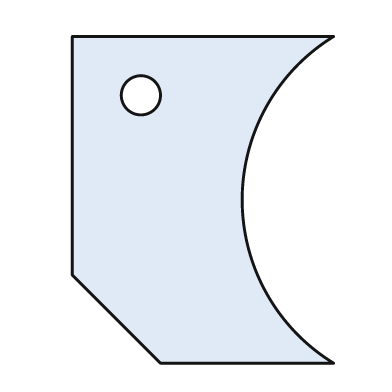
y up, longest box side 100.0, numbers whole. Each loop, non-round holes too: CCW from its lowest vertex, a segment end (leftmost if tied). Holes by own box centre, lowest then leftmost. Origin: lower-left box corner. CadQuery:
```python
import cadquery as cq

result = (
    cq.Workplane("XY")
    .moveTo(27.0, 0.0)
    .lineTo(80.0, 0.0)
    .threePointArc((52.0, 50.0), (80.0, 100.0))
    .lineTo(0.0, 100.0)
    .lineTo(0.0, 27.0)
    .close()
    .moveTo(21.0, 82.0)
    .circle(6.0)
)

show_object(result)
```